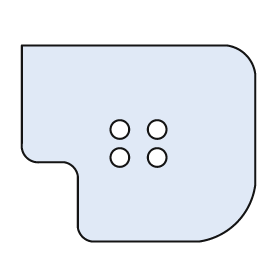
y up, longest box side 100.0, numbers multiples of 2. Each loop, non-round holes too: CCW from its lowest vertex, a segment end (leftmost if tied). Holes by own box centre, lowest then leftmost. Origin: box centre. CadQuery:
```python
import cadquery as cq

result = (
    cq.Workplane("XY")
    .moveTo(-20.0, -42.0)
    .lineTo(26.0, -42.0)
    .threePointArc((42.0, -34.0), (50.0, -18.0))
    .lineTo(50.0, 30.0)
    .threePointArc((46.0, 38.0), (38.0, 42.0))
    .lineTo(-50.0, 42.0)
    .lineTo(-50.0, 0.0)
    .threePointArc((-48.0, -6.0), (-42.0, -8.0))
    .lineTo(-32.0, -8.0)
    .threePointArc((-28.0, -10.0), (-26.0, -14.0))
    .lineTo(-26.0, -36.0)
    .threePointArc((-24.0, -40.0), (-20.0, -42.0))
    .close()
    .moveTo(-8.0, -6.0)
    .circle(4.0)
    .moveTo(8.0, -6.0)
    .circle(4.0)
    .moveTo(-8.0, 6.0)
    .circle(4.0)
    .moveTo(8.0, 6.0)
    .circle(4.0)
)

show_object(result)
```